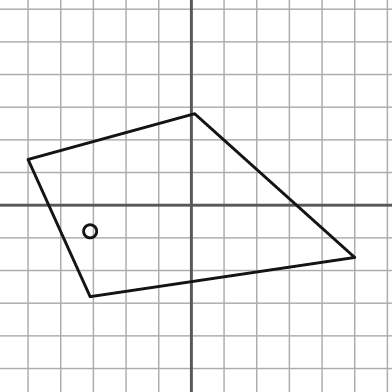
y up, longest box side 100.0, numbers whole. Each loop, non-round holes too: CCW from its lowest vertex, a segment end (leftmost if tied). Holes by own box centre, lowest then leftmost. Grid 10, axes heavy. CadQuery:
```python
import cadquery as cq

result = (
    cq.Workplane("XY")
    .moveTo(-31.0, -28.0)
    .lineTo(50.0, -16.0)
    .lineTo(1.0, 28.0)
    .lineTo(-50.0, 14.0)
    .close()
    .moveTo(-31.0, -8.0)
    .circle(2.0)
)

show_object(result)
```